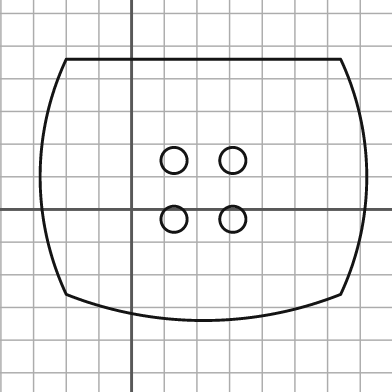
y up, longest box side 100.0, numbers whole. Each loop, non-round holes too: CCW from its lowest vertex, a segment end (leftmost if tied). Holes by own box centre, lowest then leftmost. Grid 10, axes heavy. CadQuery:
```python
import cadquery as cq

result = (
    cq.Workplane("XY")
    .moveTo(-20.0, -26.0)
    .threePointArc((22.0, -34.0), (64.0, -26.0))
    .threePointArc((72.0, 10.0), (64.0, 46.0))
    .lineTo(-20.0, 46.0)
    .threePointArc((-28.0, 10.0), (-20.0, -26.0))
    .close()
    .moveTo(13.0, -3.0)
    .circle(4.0)
    .moveTo(31.0, -3.0)
    .circle(4.0)
    .moveTo(13.0, 15.0)
    .circle(4.0)
    .moveTo(31.0, 15.0)
    .circle(4.0)
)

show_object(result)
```